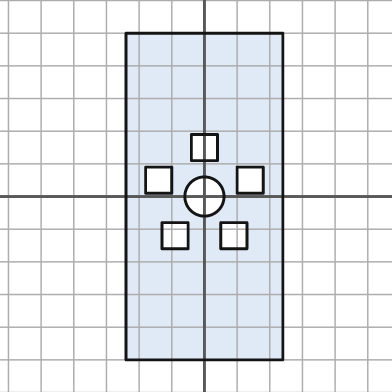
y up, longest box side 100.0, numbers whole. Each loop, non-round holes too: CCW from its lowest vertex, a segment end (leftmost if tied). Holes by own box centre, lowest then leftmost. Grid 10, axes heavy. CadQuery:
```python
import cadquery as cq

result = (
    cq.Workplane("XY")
    .moveTo(-24.0, -50.0)
    .lineTo(24.0, -50.0)
    .lineTo(24.0, 50.0)
    .lineTo(-24.0, 50.0)
    .close()
    .moveTo(-13.0, -16.0)
    .lineTo(-5.0, -16.0)
    .lineTo(-5.0, -8.0)
    .lineTo(-13.0, -8.0)
    .close()
    .moveTo(5.0, -16.0)
    .lineTo(13.0, -16.0)
    .lineTo(13.0, -8.0)
    .lineTo(5.0, -8.0)
    .close()
    .moveTo(0.0, 0.0)
    .circle(6.0)
    .moveTo(-18.0, 1.0)
    .lineTo(-10.0, 1.0)
    .lineTo(-10.0, 9.0)
    .lineTo(-18.0, 9.0)
    .close()
    .moveTo(10.0, 1.0)
    .lineTo(18.0, 1.0)
    .lineTo(18.0, 9.0)
    .lineTo(10.0, 9.0)
    .close()
    .moveTo(-4.0, 11.0)
    .lineTo(4.0, 11.0)
    .lineTo(4.0, 19.0)
    .lineTo(-4.0, 19.0)
    .close()
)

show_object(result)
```